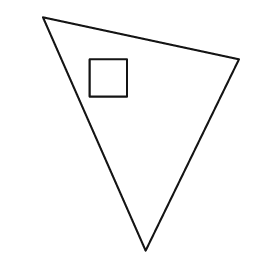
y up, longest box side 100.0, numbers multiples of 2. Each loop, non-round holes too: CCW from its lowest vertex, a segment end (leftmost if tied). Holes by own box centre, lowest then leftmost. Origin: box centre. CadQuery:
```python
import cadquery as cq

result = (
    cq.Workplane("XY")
    .moveTo(2.0, -50.0)
    .lineTo(42.0, 32.0)
    .lineTo(-42.0, 50.0)
    .close()
    .moveTo(-22.0, 16.0)
    .lineTo(-6.0, 16.0)
    .lineTo(-6.0, 32.0)
    .lineTo(-22.0, 32.0)
    .close()
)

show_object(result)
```